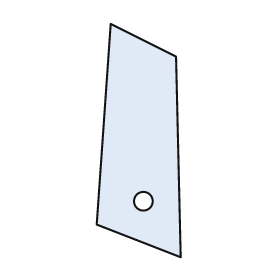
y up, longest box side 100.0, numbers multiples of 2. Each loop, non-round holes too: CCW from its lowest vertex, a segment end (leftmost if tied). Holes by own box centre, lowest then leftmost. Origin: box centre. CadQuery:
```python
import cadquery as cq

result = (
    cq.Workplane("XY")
    .moveTo(18.0, -50.0)
    .lineTo(16.0, 36.0)
    .lineTo(-12.0, 50.0)
    .lineTo(-18.0, -36.0)
    .close()
    .moveTo(2.0, -26.0)
    .circle(4.0)
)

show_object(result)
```